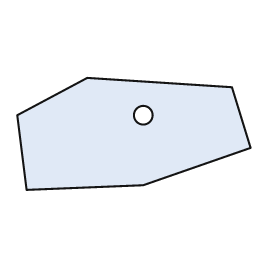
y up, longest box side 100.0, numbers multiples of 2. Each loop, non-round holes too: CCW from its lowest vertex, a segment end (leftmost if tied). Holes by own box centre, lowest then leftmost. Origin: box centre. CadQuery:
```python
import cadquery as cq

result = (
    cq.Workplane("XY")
    .moveTo(-46.0, -24.0)
    .lineTo(4.0, -22.0)
    .lineTo(50.0, -6.0)
    .lineTo(42.0, 20.0)
    .lineTo(-20.0, 24.0)
    .lineTo(-50.0, 8.0)
    .close()
    .moveTo(4.0, 8.0)
    .circle(4.0)
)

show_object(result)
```